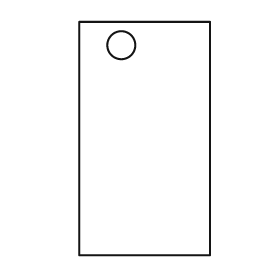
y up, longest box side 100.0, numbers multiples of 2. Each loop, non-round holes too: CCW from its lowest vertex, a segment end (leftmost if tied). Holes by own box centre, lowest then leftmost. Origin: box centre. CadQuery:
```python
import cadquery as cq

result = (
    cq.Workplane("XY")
    .moveTo(-28.0, -50.0)
    .lineTo(28.0, -50.0)
    .lineTo(28.0, 50.0)
    .lineTo(-28.0, 50.0)
    .close()
    .moveTo(-10.0, 40.0)
    .circle(6.0)
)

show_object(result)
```